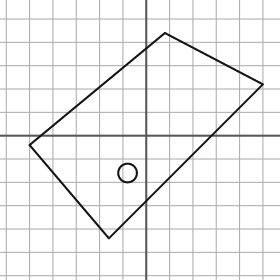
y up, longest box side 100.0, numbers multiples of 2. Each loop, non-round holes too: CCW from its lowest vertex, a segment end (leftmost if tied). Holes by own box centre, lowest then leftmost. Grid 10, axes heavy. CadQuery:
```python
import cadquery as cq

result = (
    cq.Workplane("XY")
    .moveTo(-16.0, -44.0)
    .lineTo(50.0, 22.0)
    .lineTo(8.0, 44.0)
    .lineTo(-50.0, -4.0)
    .close()
    .moveTo(-8.0, -16.0)
    .circle(4.0)
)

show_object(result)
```